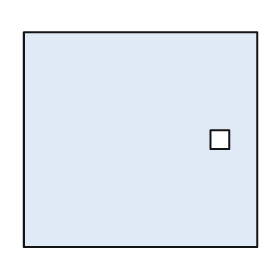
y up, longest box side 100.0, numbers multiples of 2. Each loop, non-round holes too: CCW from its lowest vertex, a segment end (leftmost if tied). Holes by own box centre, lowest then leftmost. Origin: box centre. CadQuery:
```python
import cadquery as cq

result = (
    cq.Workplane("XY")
    .moveTo(-50.0, -46.0)
    .lineTo(50.0, -46.0)
    .lineTo(50.0, 46.0)
    .lineTo(-50.0, 46.0)
    .close()
    .moveTo(30.0, -4.0)
    .lineTo(38.0, -4.0)
    .lineTo(38.0, 4.0)
    .lineTo(30.0, 4.0)
    .close()
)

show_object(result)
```